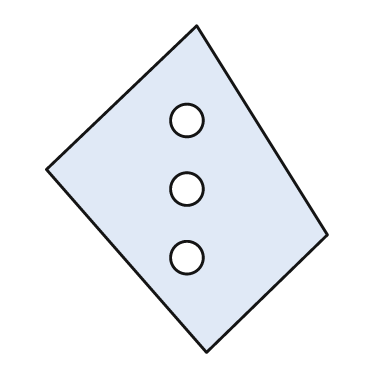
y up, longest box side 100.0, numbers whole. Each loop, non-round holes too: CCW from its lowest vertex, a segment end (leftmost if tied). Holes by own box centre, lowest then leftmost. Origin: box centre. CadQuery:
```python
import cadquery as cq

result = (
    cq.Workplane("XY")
    .moveTo(6.0, -50.0)
    .lineTo(43.0, -14.0)
    .lineTo(3.0, 50.0)
    .lineTo(-43.0, 6.0)
    .close()
    .moveTo(0.0, -21.0)
    .circle(5.0)
    .moveTo(0.0, 0.0)
    .circle(5.0)
    .moveTo(0.0, 21.0)
    .circle(5.0)
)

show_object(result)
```